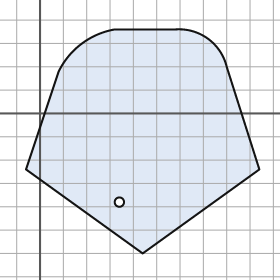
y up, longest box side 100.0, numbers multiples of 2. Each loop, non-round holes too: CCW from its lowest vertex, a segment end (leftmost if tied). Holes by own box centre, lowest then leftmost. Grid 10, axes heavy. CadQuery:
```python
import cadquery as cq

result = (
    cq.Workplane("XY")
    .moveTo(44.0, -60.0)
    .lineTo(94.0, -24.0)
    .lineTo(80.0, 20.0)
    .threePointArc((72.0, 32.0), (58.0, 36.0))
    .lineTo(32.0, 36.0)
    .threePointArc((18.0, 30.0), (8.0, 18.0))
    .lineTo(-6.0, -24.0)
    .close()
    .moveTo(34.0, -38.0)
    .circle(2.0)
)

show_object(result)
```